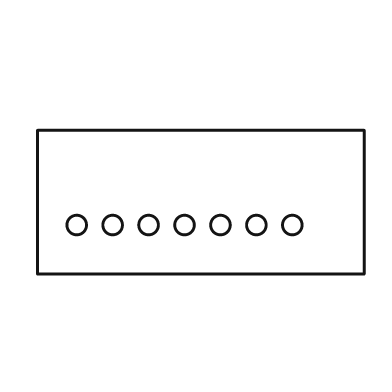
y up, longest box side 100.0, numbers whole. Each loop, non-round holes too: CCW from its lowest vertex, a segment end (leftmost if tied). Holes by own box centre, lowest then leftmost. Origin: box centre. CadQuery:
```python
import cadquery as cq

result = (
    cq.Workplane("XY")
    .moveTo(-50.0, -22.0)
    .lineTo(50.0, -22.0)
    .lineTo(50.0, 22.0)
    .lineTo(-50.0, 22.0)
    .close()
    .moveTo(-38.0, -7.0)
    .circle(3.0)
    .moveTo(-27.0, -7.0)
    .circle(3.0)
    .moveTo(-16.0, -7.0)
    .circle(3.0)
    .moveTo(-5.0, -7.0)
    .circle(3.0)
    .moveTo(6.0, -7.0)
    .circle(3.0)
    .moveTo(17.0, -7.0)
    .circle(3.0)
    .moveTo(28.0, -7.0)
    .circle(3.0)
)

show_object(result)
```